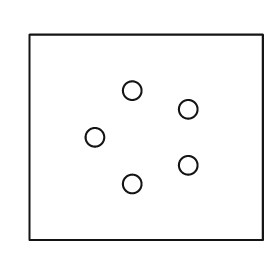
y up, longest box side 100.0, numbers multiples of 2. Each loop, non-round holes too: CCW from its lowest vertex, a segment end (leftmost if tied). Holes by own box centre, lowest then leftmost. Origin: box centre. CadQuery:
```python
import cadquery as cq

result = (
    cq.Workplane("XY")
    .moveTo(-50.0, -44.0)
    .lineTo(50.0, -44.0)
    .lineTo(50.0, 44.0)
    .lineTo(-50.0, 44.0)
    .close()
    .moveTo(-6.0, -20.0)
    .circle(4.0)
    .moveTo(18.0, -12.0)
    .circle(4.0)
    .moveTo(-22.0, 0.0)
    .circle(4.0)
    .moveTo(18.0, 12.0)
    .circle(4.0)
    .moveTo(-6.0, 20.0)
    .circle(4.0)
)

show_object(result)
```